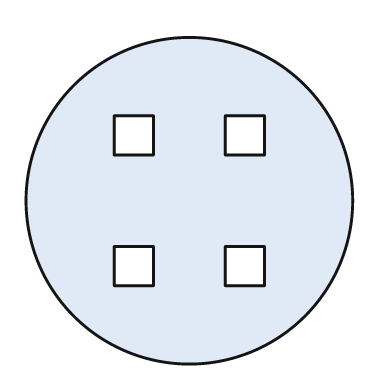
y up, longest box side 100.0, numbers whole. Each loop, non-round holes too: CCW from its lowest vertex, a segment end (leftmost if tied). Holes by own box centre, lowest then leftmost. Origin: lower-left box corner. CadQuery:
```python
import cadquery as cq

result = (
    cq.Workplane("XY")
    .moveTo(50.0, 50.0)
    .circle(50.0)
    .moveTo(27.0, 24.0)
    .lineTo(39.0, 24.0)
    .lineTo(39.0, 36.0)
    .lineTo(27.0, 36.0)
    .close()
    .moveTo(61.0, 24.0)
    .lineTo(73.0, 24.0)
    .lineTo(73.0, 36.0)
    .lineTo(61.0, 36.0)
    .close()
    .moveTo(27.0, 64.0)
    .lineTo(39.0, 64.0)
    .lineTo(39.0, 76.0)
    .lineTo(27.0, 76.0)
    .close()
    .moveTo(61.0, 64.0)
    .lineTo(73.0, 64.0)
    .lineTo(73.0, 76.0)
    .lineTo(61.0, 76.0)
    .close()
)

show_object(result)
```